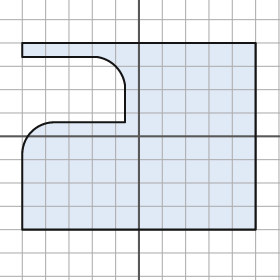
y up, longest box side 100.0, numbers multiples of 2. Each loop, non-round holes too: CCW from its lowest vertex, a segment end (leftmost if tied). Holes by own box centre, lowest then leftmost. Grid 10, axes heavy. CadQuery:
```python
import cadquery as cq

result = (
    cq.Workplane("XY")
    .moveTo(-50.0, -40.0)
    .lineTo(50.0, -40.0)
    .lineTo(50.0, 40.0)
    .lineTo(-50.0, 40.0)
    .lineTo(-50.0, 34.0)
    .lineTo(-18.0, 34.0)
    .threePointArc((-10.0, 30.0), (-6.0, 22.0))
    .lineTo(-6.0, 6.0)
    .lineTo(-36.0, 6.0)
    .threePointArc((-46.0, 2.0), (-50.0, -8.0))
    .close()
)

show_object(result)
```